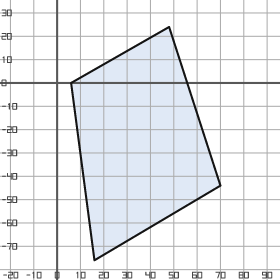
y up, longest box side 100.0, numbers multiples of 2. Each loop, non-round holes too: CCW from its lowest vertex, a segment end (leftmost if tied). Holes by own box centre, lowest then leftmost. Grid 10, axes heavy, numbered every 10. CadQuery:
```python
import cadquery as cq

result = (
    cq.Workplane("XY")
    .moveTo(16.0, -76.0)
    .lineTo(70.0, -44.0)
    .lineTo(48.0, 24.0)
    .lineTo(6.0, 0.0)
    .close()
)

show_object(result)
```